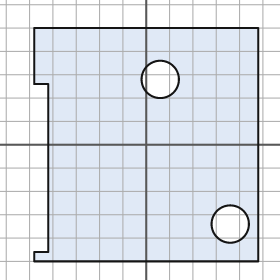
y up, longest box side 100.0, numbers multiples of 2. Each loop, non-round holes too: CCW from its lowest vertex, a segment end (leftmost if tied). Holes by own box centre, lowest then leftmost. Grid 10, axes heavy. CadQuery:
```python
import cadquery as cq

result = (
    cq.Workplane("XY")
    .moveTo(-48.0, -50.0)
    .lineTo(48.0, -50.0)
    .lineTo(48.0, 50.0)
    .lineTo(-48.0, 50.0)
    .lineTo(-48.0, 26.0)
    .lineTo(-42.0, 26.0)
    .lineTo(-42.0, -46.0)
    .lineTo(-48.0, -46.0)
    .close()
    .moveTo(36.0, -34.0)
    .circle(8.0)
    .moveTo(6.0, 28.0)
    .circle(8.0)
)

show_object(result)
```